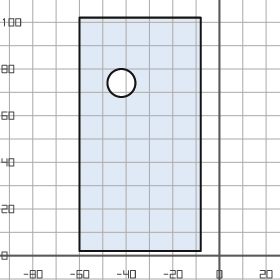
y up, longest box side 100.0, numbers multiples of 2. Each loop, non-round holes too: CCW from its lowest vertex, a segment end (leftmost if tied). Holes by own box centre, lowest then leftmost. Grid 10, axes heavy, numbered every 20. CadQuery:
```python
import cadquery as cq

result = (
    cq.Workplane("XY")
    .moveTo(-60.0, 2.0)
    .lineTo(-8.0, 2.0)
    .lineTo(-8.0, 102.0)
    .lineTo(-60.0, 102.0)
    .close()
    .moveTo(-42.0, 74.0)
    .circle(6.0)
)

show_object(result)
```